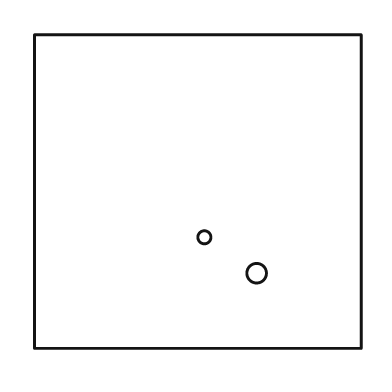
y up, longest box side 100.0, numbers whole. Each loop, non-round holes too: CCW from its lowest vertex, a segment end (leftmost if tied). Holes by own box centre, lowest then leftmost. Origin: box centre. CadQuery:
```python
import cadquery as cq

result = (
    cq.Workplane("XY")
    .moveTo(-50.0, -48.0)
    .lineTo(50.0, -48.0)
    .lineTo(50.0, 48.0)
    .lineTo(-50.0, 48.0)
    .close()
    .moveTo(18.0, -25.0)
    .circle(3.0)
    .moveTo(2.0, -14.0)
    .circle(2.0)
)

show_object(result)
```